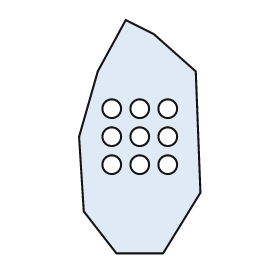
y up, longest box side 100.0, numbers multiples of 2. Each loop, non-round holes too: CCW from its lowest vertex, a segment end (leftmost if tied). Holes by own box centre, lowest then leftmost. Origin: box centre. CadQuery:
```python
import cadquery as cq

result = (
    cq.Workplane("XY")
    .moveTo(-10.0, -50.0)
    .lineTo(10.0, -50.0)
    .lineTo(26.0, -24.0)
    .lineTo(24.0, 28.0)
    .lineTo(6.0, 44.0)
    .lineTo(-6.0, 50.0)
    .lineTo(-18.0, 28.0)
    .lineTo(-26.0, 0.0)
    .lineTo(-24.0, -32.0)
    .close()
    .moveTo(-12.0, -12.0)
    .circle(4.0)
    .moveTo(0.0, -12.0)
    .circle(4.0)
    .moveTo(12.0, -12.0)
    .circle(4.0)
    .moveTo(-12.0, 0.0)
    .circle(4.0)
    .moveTo(0.0, 0.0)
    .circle(4.0)
    .moveTo(12.0, 0.0)
    .circle(4.0)
    .moveTo(-12.0, 12.0)
    .circle(4.0)
    .moveTo(0.0, 12.0)
    .circle(4.0)
    .moveTo(12.0, 12.0)
    .circle(4.0)
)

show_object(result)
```